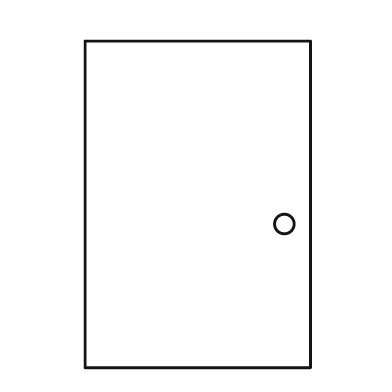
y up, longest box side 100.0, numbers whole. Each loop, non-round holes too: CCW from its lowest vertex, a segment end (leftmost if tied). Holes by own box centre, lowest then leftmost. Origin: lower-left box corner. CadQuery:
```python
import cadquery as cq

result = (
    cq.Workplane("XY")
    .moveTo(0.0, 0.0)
    .lineTo(69.0, 0.0)
    .lineTo(69.0, 100.0)
    .lineTo(0.0, 100.0)
    .close()
    .moveTo(61.0, 44.0)
    .circle(3.0)
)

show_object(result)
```